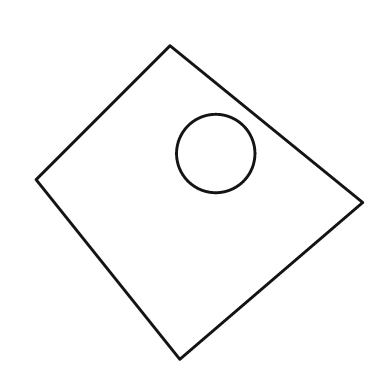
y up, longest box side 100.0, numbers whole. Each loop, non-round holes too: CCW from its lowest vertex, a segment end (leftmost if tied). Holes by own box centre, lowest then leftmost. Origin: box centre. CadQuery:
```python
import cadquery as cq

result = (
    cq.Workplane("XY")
    .moveTo(-6.0, -48.0)
    .lineTo(50.0, 0.0)
    .lineTo(-9.0, 48.0)
    .lineTo(-50.0, 7.0)
    .close()
    .moveTo(5.0, 15.0)
    .circle(12.0)
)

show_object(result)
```